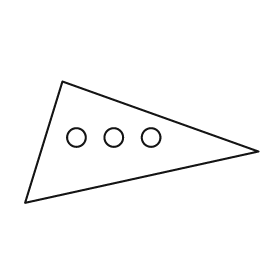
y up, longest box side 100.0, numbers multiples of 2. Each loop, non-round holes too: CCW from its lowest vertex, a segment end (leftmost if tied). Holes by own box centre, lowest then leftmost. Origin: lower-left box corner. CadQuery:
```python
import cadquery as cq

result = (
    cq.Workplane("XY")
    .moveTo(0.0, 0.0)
    .lineTo(100.0, 22.0)
    .lineTo(16.0, 52.0)
    .close()
    .moveTo(22.0, 28.0)
    .circle(4.0)
    .moveTo(38.0, 28.0)
    .circle(4.0)
    .moveTo(54.0, 28.0)
    .circle(4.0)
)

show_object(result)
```